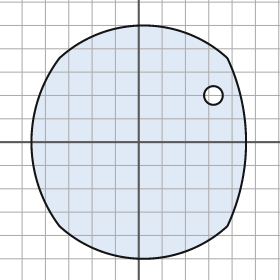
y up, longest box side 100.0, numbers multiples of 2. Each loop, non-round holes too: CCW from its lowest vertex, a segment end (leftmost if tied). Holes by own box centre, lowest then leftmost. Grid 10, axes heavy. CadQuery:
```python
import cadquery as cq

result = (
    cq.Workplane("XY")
    .moveTo(-34.0, -36.0)
    .threePointArc((2.0, -50.0), (38.0, -36.0))
    .threePointArc((46.0, 0.0), (38.0, 36.0))
    .threePointArc((2.0, 50.0), (-34.0, 36.0))
    .threePointArc((-46.0, 0.0), (-34.0, -36.0))
    .close()
    .moveTo(32.0, 20.0)
    .circle(4.0)
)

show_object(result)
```